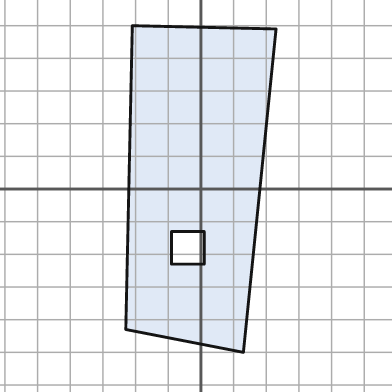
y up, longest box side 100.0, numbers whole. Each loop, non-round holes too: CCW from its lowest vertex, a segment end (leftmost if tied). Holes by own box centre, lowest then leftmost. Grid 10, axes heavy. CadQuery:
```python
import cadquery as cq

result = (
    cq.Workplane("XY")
    .moveTo(13.0, -50.0)
    .lineTo(23.0, 49.0)
    .lineTo(-21.0, 50.0)
    .lineTo(-23.0, -43.0)
    .close()
    .moveTo(-9.0, -23.0)
    .lineTo(1.0, -23.0)
    .lineTo(1.0, -13.0)
    .lineTo(-9.0, -13.0)
    .close()
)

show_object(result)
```